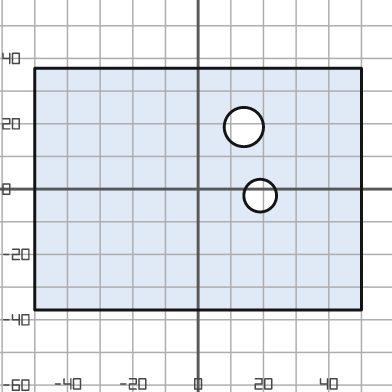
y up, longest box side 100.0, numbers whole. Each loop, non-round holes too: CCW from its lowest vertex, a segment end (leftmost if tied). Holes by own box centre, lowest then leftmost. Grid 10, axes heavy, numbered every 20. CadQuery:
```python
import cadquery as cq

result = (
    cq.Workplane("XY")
    .moveTo(-50.0, -37.0)
    .lineTo(50.0, -37.0)
    .lineTo(50.0, 37.0)
    .lineTo(-50.0, 37.0)
    .close()
    .moveTo(19.0, -2.0)
    .circle(5.0)
    .moveTo(14.0, 19.0)
    .circle(6.0)
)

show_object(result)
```